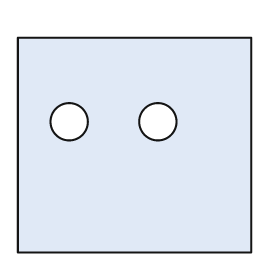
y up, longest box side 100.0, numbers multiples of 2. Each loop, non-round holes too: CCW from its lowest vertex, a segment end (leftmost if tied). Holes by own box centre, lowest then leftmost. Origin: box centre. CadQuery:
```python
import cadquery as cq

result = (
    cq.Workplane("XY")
    .moveTo(-50.0, -46.0)
    .lineTo(50.0, -46.0)
    .lineTo(50.0, 46.0)
    .lineTo(-50.0, 46.0)
    .close()
    .moveTo(-28.0, 10.0)
    .circle(8.0)
    .moveTo(10.0, 10.0)
    .circle(8.0)
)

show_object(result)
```